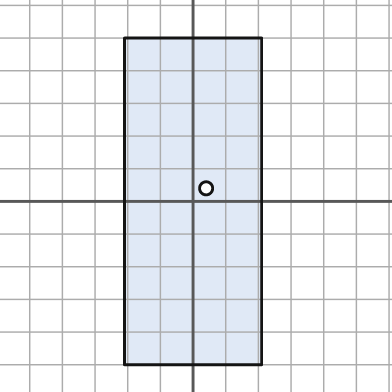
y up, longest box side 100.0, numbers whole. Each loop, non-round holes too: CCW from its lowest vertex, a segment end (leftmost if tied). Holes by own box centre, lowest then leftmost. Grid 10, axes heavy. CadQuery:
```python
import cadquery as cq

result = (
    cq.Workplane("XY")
    .moveTo(-21.0, -50.0)
    .lineTo(21.0, -50.0)
    .lineTo(21.0, 50.0)
    .lineTo(-21.0, 50.0)
    .close()
    .moveTo(4.0, 4.0)
    .circle(2.0)
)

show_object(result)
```